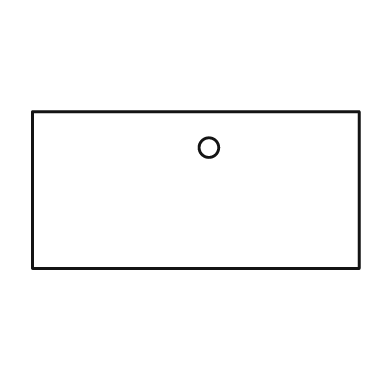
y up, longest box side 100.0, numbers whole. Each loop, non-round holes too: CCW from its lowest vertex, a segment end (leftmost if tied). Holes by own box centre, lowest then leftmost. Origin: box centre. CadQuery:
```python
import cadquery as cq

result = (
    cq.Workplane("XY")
    .moveTo(-50.0, -24.0)
    .lineTo(50.0, -24.0)
    .lineTo(50.0, 24.0)
    .lineTo(-50.0, 24.0)
    .close()
    .moveTo(4.0, 13.0)
    .circle(3.0)
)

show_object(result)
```